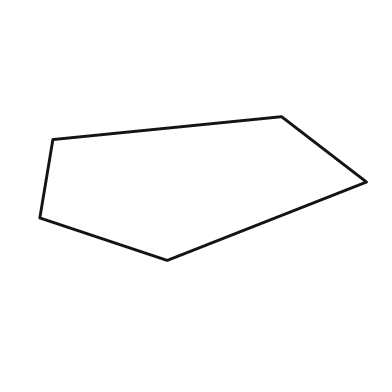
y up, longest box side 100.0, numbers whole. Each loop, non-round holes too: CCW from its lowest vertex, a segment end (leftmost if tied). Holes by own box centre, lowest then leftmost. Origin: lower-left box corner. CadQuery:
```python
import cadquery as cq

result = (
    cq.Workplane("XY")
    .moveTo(39.0, 0.0)
    .lineTo(100.0, 24.0)
    .lineTo(74.0, 44.0)
    .lineTo(4.0, 37.0)
    .lineTo(0.0, 13.0)
    .close()
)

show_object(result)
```